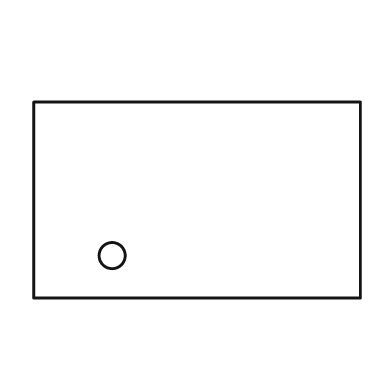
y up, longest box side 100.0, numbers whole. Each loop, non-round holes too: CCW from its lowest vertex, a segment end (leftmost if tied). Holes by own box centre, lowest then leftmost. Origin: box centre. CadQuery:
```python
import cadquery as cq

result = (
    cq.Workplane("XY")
    .moveTo(-50.0, -30.0)
    .lineTo(50.0, -30.0)
    .lineTo(50.0, 30.0)
    .lineTo(-50.0, 30.0)
    .close()
    .moveTo(-26.0, -17.0)
    .circle(4.0)
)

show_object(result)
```